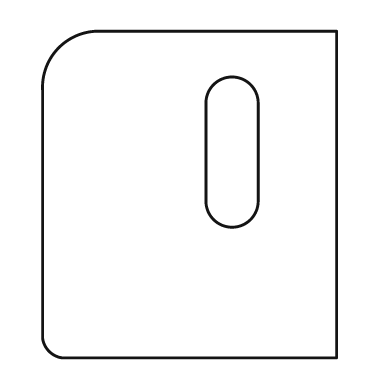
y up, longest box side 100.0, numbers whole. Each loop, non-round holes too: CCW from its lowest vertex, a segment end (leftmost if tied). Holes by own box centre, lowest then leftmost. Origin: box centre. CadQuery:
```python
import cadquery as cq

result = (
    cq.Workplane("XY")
    .moveTo(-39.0, -50.0)
    .lineTo(45.0, -50.0)
    .lineTo(45.0, 50.0)
    .lineTo(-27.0, 50.0)
    .threePointArc((-40.0, 45.0), (-45.0, 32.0))
    .lineTo(-45.0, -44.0)
    .threePointArc((-43.0, -48.0), (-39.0, -50.0))
    .close()
    .moveTo(5.0, -2.0)
    .threePointArc((13.0, -10.0), (21.0, -2.0))
    .lineTo(21.0, 28.0)
    .threePointArc((13.0, 36.0), (5.0, 28.0))
    .close()
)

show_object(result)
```